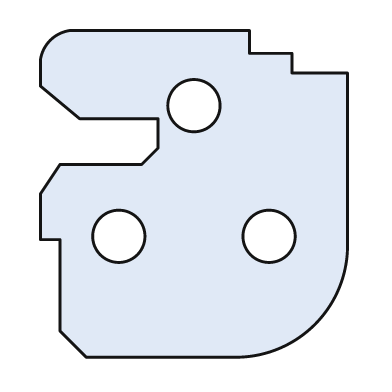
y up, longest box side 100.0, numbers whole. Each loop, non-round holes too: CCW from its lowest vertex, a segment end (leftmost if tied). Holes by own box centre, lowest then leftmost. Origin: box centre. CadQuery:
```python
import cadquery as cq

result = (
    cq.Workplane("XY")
    .moveTo(-33.0, -50.0)
    .lineTo(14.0, -50.0)
    .threePointArc((37.0, -40.0), (47.0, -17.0))
    .lineTo(47.0, 37.0)
    .lineTo(30.0, 37.0)
    .lineTo(30.0, 43.0)
    .lineTo(17.0, 43.0)
    .lineTo(17.0, 50.0)
    .lineTo(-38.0, 50.0)
    .threePointArc((-44.0, 47.0), (-47.0, 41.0))
    .lineTo(-47.0, 33.0)
    .lineTo(-35.0, 23.0)
    .lineTo(-11.0, 23.0)
    .lineTo(-11.0, 14.0)
    .lineTo(-16.0, 9.0)
    .lineTo(-41.0, 9.0)
    .lineTo(-47.0, 0.0)
    .lineTo(-47.0, -14.0)
    .lineTo(-41.0, -14.0)
    .lineTo(-41.0, -42.0)
    .close()
    .moveTo(-23.0, -13.0)
    .circle(8.0)
    .moveTo(23.0, -13.0)
    .circle(8.0)
    .moveTo(0.0, 27.0)
    .circle(8.0)
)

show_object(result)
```